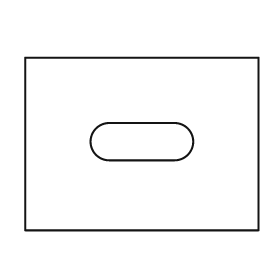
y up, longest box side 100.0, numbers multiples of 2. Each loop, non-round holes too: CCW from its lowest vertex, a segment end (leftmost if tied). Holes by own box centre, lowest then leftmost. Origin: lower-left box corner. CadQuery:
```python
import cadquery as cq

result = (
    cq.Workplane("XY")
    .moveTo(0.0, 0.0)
    .lineTo(100.0, 0.0)
    .lineTo(100.0, 74.0)
    .lineTo(0.0, 74.0)
    .close()
    .moveTo(36.0, 30.0)
    .lineTo(64.0, 30.0)
    .threePointArc((72.0, 38.0), (64.0, 46.0))
    .lineTo(36.0, 46.0)
    .threePointArc((28.0, 38.0), (36.0, 30.0))
    .close()
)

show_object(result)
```